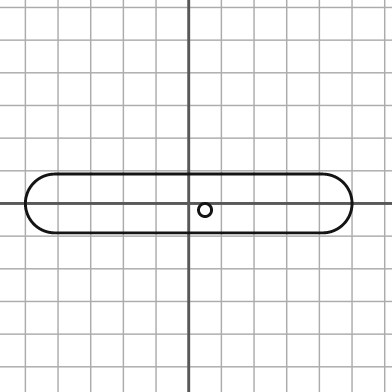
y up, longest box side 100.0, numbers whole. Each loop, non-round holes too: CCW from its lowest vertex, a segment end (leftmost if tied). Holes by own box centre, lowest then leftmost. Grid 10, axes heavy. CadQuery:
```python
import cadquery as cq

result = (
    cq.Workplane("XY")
    .moveTo(-41.0, -9.0)
    .lineTo(41.0, -9.0)
    .threePointArc((50.0, 0.0), (41.0, 9.0))
    .lineTo(-41.0, 9.0)
    .threePointArc((-50.0, 0.0), (-41.0, -9.0))
    .close()
    .moveTo(5.0, -2.0)
    .circle(2.0)
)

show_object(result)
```